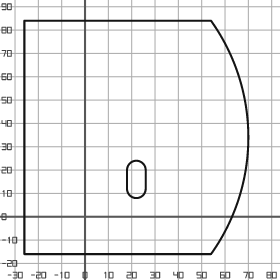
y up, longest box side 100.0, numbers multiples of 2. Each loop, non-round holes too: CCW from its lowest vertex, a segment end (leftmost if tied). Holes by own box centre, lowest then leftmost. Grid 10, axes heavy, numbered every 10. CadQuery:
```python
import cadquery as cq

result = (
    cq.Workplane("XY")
    .moveTo(-26.0, -16.0)
    .lineTo(54.0, -16.0)
    .threePointArc((70.0, 34.0), (54.0, 84.0))
    .lineTo(-26.0, 84.0)
    .close()
    .moveTo(18.0, 12.0)
    .threePointArc((22.0, 8.0), (26.0, 12.0))
    .lineTo(26.0, 20.0)
    .threePointArc((22.0, 24.0), (18.0, 20.0))
    .close()
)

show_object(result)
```